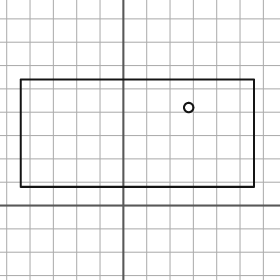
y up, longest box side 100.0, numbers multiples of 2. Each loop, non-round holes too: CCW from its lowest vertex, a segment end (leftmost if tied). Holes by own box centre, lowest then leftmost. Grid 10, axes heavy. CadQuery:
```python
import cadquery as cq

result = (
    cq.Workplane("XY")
    .moveTo(-44.0, 8.0)
    .lineTo(56.0, 8.0)
    .lineTo(56.0, 54.0)
    .lineTo(-44.0, 54.0)
    .close()
    .moveTo(28.0, 42.0)
    .circle(2.0)
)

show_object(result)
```